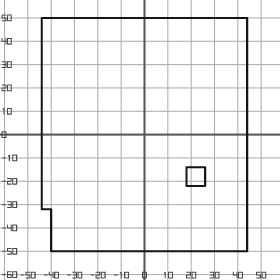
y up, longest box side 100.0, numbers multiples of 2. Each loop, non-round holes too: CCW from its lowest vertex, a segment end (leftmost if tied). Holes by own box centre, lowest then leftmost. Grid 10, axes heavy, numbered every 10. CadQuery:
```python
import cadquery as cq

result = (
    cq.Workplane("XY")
    .moveTo(-40.0, -50.0)
    .lineTo(44.0, -50.0)
    .lineTo(44.0, 50.0)
    .lineTo(-44.0, 50.0)
    .lineTo(-44.0, -32.0)
    .lineTo(-40.0, -32.0)
    .close()
    .moveTo(18.0, -22.0)
    .lineTo(26.0, -22.0)
    .lineTo(26.0, -14.0)
    .lineTo(18.0, -14.0)
    .close()
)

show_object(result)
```